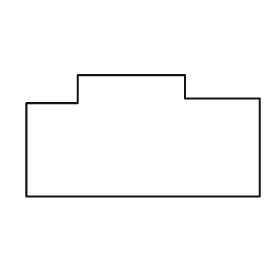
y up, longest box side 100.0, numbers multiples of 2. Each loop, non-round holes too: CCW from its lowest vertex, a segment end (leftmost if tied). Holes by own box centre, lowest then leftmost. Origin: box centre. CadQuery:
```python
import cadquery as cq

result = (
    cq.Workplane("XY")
    .moveTo(-50.0, -26.0)
    .lineTo(50.0, -26.0)
    .lineTo(50.0, 16.0)
    .lineTo(18.0, 16.0)
    .lineTo(18.0, 26.0)
    .lineTo(-28.0, 26.0)
    .lineTo(-28.0, 14.0)
    .lineTo(-50.0, 14.0)
    .close()
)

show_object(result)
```